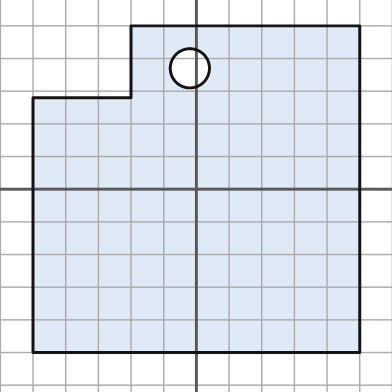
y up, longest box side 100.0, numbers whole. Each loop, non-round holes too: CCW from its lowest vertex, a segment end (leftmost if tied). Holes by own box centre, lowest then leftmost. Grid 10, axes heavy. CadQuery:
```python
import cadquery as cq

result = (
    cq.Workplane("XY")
    .moveTo(-50.0, -50.0)
    .lineTo(50.0, -50.0)
    .lineTo(50.0, 50.0)
    .lineTo(-20.0, 50.0)
    .lineTo(-20.0, 28.0)
    .lineTo(-50.0, 28.0)
    .close()
    .moveTo(-2.0, 37.0)
    .circle(6.0)
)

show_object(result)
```